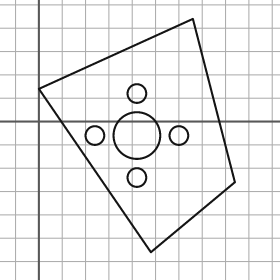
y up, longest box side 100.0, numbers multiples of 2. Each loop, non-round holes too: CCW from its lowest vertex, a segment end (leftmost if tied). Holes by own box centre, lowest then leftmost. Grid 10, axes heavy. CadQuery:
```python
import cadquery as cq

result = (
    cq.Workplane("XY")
    .moveTo(48.0, -56.0)
    .lineTo(84.0, -26.0)
    .lineTo(66.0, 44.0)
    .lineTo(0.0, 14.0)
    .close()
    .moveTo(42.0, -24.0)
    .circle(4.0)
    .moveTo(24.0, -6.0)
    .circle(4.0)
    .moveTo(42.0, -6.0)
    .circle(10.0)
    .moveTo(60.0, -6.0)
    .circle(4.0)
    .moveTo(42.0, 12.0)
    .circle(4.0)
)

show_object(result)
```